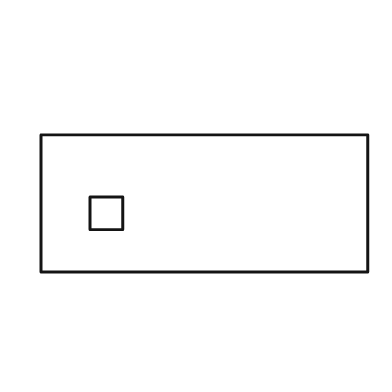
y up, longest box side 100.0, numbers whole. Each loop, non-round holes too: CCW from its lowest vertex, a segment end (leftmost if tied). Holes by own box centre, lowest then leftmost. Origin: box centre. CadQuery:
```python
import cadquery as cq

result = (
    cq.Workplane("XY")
    .moveTo(-50.0, -21.0)
    .lineTo(50.0, -21.0)
    .lineTo(50.0, 21.0)
    .lineTo(-50.0, 21.0)
    .close()
    .moveTo(-35.0, -8.0)
    .lineTo(-25.0, -8.0)
    .lineTo(-25.0, 2.0)
    .lineTo(-35.0, 2.0)
    .close()
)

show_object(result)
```